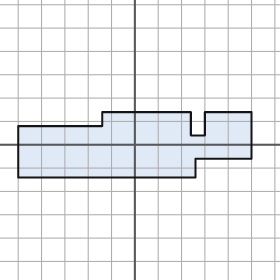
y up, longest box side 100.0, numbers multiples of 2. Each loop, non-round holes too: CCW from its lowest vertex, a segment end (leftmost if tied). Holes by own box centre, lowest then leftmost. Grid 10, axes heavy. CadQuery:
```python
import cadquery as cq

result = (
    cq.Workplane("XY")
    .moveTo(-50.0, -14.0)
    .lineTo(26.0, -14.0)
    .lineTo(26.0, -6.0)
    .lineTo(50.0, -6.0)
    .lineTo(50.0, 14.0)
    .lineTo(30.0, 14.0)
    .lineTo(30.0, 4.0)
    .lineTo(24.0, 4.0)
    .lineTo(24.0, 14.0)
    .lineTo(-14.0, 14.0)
    .lineTo(-14.0, 8.0)
    .lineTo(-50.0, 8.0)
    .close()
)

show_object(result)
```